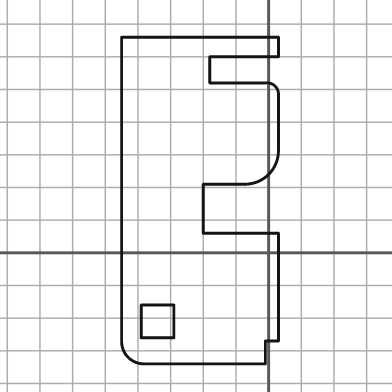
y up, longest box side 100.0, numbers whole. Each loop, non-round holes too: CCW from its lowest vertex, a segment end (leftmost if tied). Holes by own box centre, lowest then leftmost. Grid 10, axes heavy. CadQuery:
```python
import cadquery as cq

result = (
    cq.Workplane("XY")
    .moveTo(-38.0, -34.0)
    .lineTo(-1.0, -34.0)
    .lineTo(-1.0, -27.0)
    .lineTo(3.0, -27.0)
    .lineTo(3.0, 6.0)
    .lineTo(-20.0, 6.0)
    .lineTo(-20.0, 21.0)
    .lineTo(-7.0, 21.0)
    .threePointArc((0.0, 24.0), (3.0, 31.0))
    .lineTo(3.0, 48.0)
    .threePointArc((2.0, 51.0), (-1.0, 52.0))
    .lineTo(-18.0, 52.0)
    .lineTo(-18.0, 60.0)
    .lineTo(3.0, 60.0)
    .lineTo(3.0, 66.0)
    .lineTo(-45.0, 66.0)
    .lineTo(-45.0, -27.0)
    .threePointArc((-43.0, -32.0), (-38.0, -34.0))
    .close()
    .moveTo(-39.0, -26.0)
    .lineTo(-29.0, -26.0)
    .lineTo(-29.0, -16.0)
    .lineTo(-39.0, -16.0)
    .close()
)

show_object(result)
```